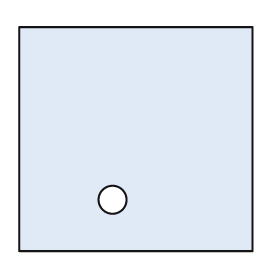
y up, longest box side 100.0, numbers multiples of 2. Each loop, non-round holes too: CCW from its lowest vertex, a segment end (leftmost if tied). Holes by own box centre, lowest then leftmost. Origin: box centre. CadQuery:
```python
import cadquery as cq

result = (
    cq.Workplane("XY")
    .moveTo(-50.0, -48.0)
    .lineTo(50.0, -48.0)
    .lineTo(50.0, 48.0)
    .lineTo(-50.0, 48.0)
    .close()
    .moveTo(-10.0, -26.0)
    .circle(6.0)
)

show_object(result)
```